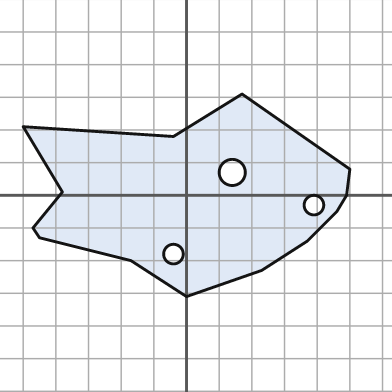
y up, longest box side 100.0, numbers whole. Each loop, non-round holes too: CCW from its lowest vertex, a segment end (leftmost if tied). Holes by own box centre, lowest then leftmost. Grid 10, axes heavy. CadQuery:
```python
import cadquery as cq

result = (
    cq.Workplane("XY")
    .moveTo(0.0, -31.0)
    .lineTo(23.0, -23.0)
    .lineTo(37.0, -14.0)
    .lineTo(46.0, -5.0)
    .lineTo(49.0, 0.0)
    .lineTo(50.0, 8.0)
    .lineTo(17.0, 31.0)
    .lineTo(-4.0, 18.0)
    .lineTo(-50.0, 21.0)
    .lineTo(-38.0, 1.0)
    .lineTo(-47.0, -10.0)
    .lineTo(-45.0, -13.0)
    .lineTo(-17.0, -20.0)
    .close()
    .moveTo(-4.0, -18.0)
    .circle(3.0)
    .moveTo(39.0, -3.0)
    .circle(3.0)
    .moveTo(14.0, 7.0)
    .circle(4.0)
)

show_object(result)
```